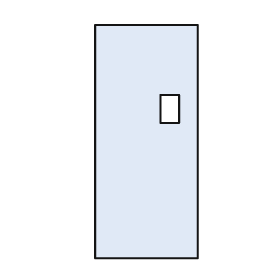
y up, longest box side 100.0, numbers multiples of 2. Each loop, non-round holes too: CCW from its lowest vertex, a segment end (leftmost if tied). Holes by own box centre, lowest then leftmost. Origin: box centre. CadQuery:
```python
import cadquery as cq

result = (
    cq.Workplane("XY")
    .moveTo(-22.0, -50.0)
    .lineTo(22.0, -50.0)
    .lineTo(22.0, 50.0)
    .lineTo(-22.0, 50.0)
    .close()
    .moveTo(6.0, 8.0)
    .lineTo(14.0, 8.0)
    .lineTo(14.0, 20.0)
    .lineTo(6.0, 20.0)
    .close()
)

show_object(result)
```